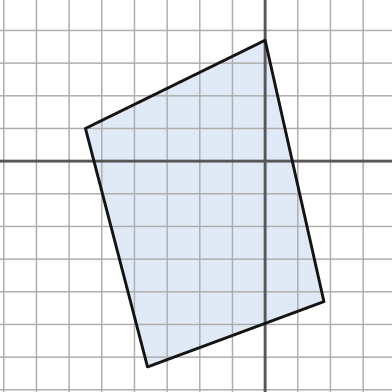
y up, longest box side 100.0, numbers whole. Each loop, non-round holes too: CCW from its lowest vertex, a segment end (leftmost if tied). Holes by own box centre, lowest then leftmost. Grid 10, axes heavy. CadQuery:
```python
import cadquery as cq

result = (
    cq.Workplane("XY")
    .moveTo(-36.0, -63.0)
    .lineTo(18.0, -43.0)
    .lineTo(0.0, 37.0)
    .lineTo(-55.0, 10.0)
    .close()
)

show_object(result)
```